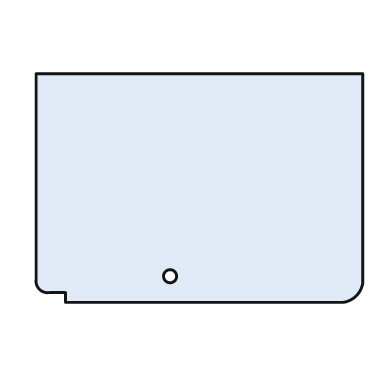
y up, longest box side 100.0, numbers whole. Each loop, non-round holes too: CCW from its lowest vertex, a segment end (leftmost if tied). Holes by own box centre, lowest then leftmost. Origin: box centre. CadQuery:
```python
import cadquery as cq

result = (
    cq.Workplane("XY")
    .moveTo(-41.0, -35.0)
    .lineTo(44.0, -35.0)
    .threePointArc((48.0, -33.0), (50.0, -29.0))
    .lineTo(50.0, 35.0)
    .lineTo(-50.0, 35.0)
    .lineTo(-50.0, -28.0)
    .threePointArc((-49.0, -31.0), (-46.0, -32.0))
    .lineTo(-41.0, -32.0)
    .close()
    .moveTo(-9.0, -27.0)
    .circle(2.0)
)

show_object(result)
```